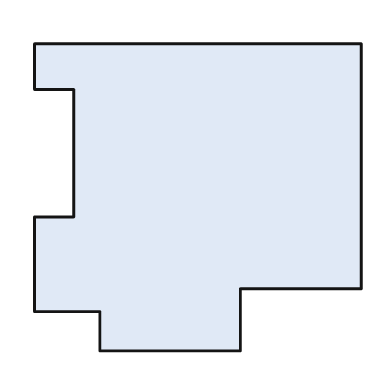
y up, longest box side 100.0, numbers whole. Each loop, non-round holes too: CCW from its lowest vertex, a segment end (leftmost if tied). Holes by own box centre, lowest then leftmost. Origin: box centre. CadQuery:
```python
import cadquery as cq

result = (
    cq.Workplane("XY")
    .moveTo(-30.0, -47.0)
    .lineTo(13.0, -47.0)
    .lineTo(13.0, -28.0)
    .lineTo(50.0, -28.0)
    .lineTo(50.0, 47.0)
    .lineTo(-50.0, 47.0)
    .lineTo(-50.0, 33.0)
    .lineTo(-38.0, 33.0)
    .lineTo(-38.0, -6.0)
    .lineTo(-50.0, -6.0)
    .lineTo(-50.0, -35.0)
    .lineTo(-30.0, -35.0)
    .close()
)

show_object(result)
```